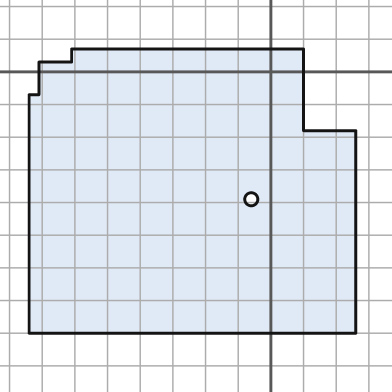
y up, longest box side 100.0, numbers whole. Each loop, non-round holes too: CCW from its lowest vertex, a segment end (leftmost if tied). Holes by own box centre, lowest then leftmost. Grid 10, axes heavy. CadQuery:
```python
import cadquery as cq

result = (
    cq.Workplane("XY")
    .moveTo(-74.0, -80.0)
    .lineTo(26.0, -80.0)
    .lineTo(26.0, -18.0)
    .lineTo(10.0, -18.0)
    .lineTo(10.0, 7.0)
    .lineTo(-61.0, 7.0)
    .lineTo(-61.0, 3.0)
    .lineTo(-71.0, 3.0)
    .lineTo(-71.0, -7.0)
    .lineTo(-74.0, -7.0)
    .close()
    .moveTo(-6.0, -39.0)
    .circle(2.0)
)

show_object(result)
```